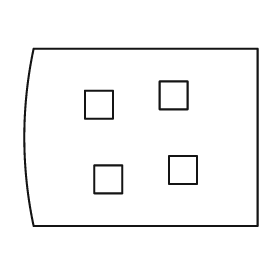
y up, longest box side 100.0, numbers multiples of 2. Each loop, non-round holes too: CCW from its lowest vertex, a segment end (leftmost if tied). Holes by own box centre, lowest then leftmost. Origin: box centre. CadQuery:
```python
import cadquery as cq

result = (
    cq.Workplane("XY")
    .moveTo(-46.0, -38.0)
    .lineTo(50.0, -38.0)
    .lineTo(50.0, 38.0)
    .lineTo(-46.0, 38.0)
    .threePointArc((-50.0, 0.0), (-46.0, -38.0))
    .close()
    .moveTo(-20.0, -24.0)
    .lineTo(-8.0, -24.0)
    .lineTo(-8.0, -12.0)
    .lineTo(-20.0, -12.0)
    .close()
    .moveTo(12.0, -20.0)
    .lineTo(24.0, -20.0)
    .lineTo(24.0, -8.0)
    .lineTo(12.0, -8.0)
    .close()
    .moveTo(-24.0, 8.0)
    .lineTo(-12.0, 8.0)
    .lineTo(-12.0, 20.0)
    .lineTo(-24.0, 20.0)
    .close()
    .moveTo(8.0, 12.0)
    .lineTo(20.0, 12.0)
    .lineTo(20.0, 24.0)
    .lineTo(8.0, 24.0)
    .close()
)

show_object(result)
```